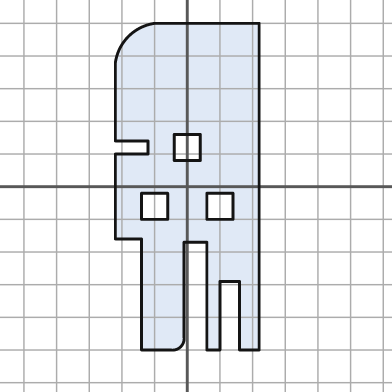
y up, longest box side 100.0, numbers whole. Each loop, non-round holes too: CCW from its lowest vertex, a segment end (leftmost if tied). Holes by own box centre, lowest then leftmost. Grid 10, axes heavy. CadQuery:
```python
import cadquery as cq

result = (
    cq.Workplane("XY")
    .moveTo(-14.0, -50.0)
    .lineTo(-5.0, -50.0)
    .threePointArc((-2.0, -49.0), (-1.0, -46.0))
    .lineTo(-1.0, -17.0)
    .lineTo(6.0, -17.0)
    .lineTo(6.0, -50.0)
    .lineTo(10.0, -50.0)
    .lineTo(10.0, -29.0)
    .lineTo(16.0, -29.0)
    .lineTo(16.0, -50.0)
    .lineTo(22.0, -50.0)
    .lineTo(22.0, 50.0)
    .lineTo(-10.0, 50.0)
    .threePointArc((-18.0, 46.0), (-22.0, 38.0))
    .lineTo(-22.0, 14.0)
    .lineTo(-12.0, 14.0)
    .lineTo(-12.0, 10.0)
    .lineTo(-22.0, 10.0)
    .lineTo(-22.0, -16.0)
    .lineTo(-14.0, -16.0)
    .close()
    .moveTo(-14.0, -10.0)
    .lineTo(-6.0, -10.0)
    .lineTo(-6.0, -2.0)
    .lineTo(-14.0, -2.0)
    .close()
    .moveTo(6.0, -10.0)
    .lineTo(14.0, -10.0)
    .lineTo(14.0, -2.0)
    .lineTo(6.0, -2.0)
    .close()
    .moveTo(-4.0, 8.0)
    .lineTo(4.0, 8.0)
    .lineTo(4.0, 16.0)
    .lineTo(-4.0, 16.0)
    .close()
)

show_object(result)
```